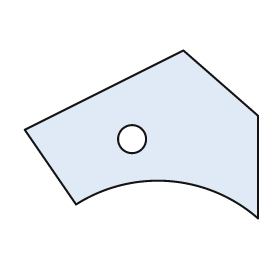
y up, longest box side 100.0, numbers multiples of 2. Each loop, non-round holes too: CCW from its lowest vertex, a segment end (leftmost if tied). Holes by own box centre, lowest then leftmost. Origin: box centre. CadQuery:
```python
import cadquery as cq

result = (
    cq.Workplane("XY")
    .moveTo(50.0, -36.0)
    .lineTo(50.0, 8.0)
    .lineTo(18.0, 36.0)
    .lineTo(-50.0, 2.0)
    .lineTo(-28.0, -30.0)
    .threePointArc((12.0, -20.0), (50.0, -36.0))
    .close()
    .moveTo(-4.0, -2.0)
    .circle(6.0)
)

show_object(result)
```